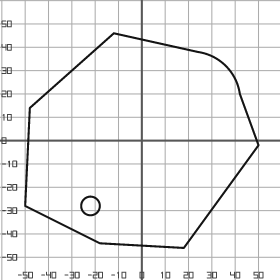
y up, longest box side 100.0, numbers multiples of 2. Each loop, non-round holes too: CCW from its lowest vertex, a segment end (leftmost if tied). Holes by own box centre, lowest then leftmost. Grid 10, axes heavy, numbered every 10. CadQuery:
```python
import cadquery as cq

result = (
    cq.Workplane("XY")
    .moveTo(18.0, -46.0)
    .lineTo(50.0, -2.0)
    .lineTo(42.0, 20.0)
    .threePointArc((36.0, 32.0), (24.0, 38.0))
    .lineTo(-12.0, 46.0)
    .lineTo(-48.0, 14.0)
    .lineTo(-50.0, -28.0)
    .lineTo(-18.0, -44.0)
    .close()
    .moveTo(-22.0, -28.0)
    .circle(4.0)
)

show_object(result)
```